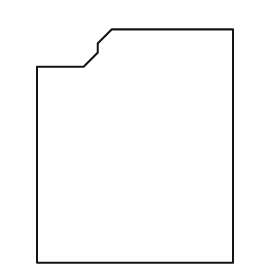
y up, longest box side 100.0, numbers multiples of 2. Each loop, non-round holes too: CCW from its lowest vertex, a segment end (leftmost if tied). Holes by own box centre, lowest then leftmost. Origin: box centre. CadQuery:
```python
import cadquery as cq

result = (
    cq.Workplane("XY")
    .moveTo(-42.0, -50.0)
    .lineTo(42.0, -50.0)
    .lineTo(42.0, 50.0)
    .lineTo(-10.0, 50.0)
    .lineTo(-16.0, 44.0)
    .lineTo(-16.0, 40.0)
    .lineTo(-22.0, 34.0)
    .lineTo(-42.0, 34.0)
    .close()
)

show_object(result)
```